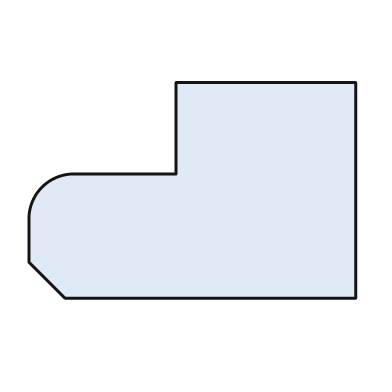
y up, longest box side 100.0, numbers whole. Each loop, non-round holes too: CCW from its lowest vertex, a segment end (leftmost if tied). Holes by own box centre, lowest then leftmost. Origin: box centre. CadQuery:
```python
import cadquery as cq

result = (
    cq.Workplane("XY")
    .moveTo(-39.0, -33.0)
    .lineTo(50.0, -33.0)
    .lineTo(50.0, 33.0)
    .lineTo(-5.0, 33.0)
    .lineTo(-5.0, 5.0)
    .lineTo(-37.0, 5.0)
    .threePointArc((-46.0, 1.0), (-50.0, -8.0))
    .lineTo(-50.0, -22.0)
    .close()
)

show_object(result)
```